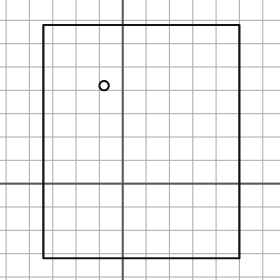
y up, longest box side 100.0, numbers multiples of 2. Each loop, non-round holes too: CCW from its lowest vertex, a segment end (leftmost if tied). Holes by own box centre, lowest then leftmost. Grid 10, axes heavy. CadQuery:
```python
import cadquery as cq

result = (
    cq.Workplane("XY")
    .moveTo(-34.0, -32.0)
    .lineTo(50.0, -32.0)
    .lineTo(50.0, 68.0)
    .lineTo(-34.0, 68.0)
    .close()
    .moveTo(-8.0, 42.0)
    .circle(2.0)
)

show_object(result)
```